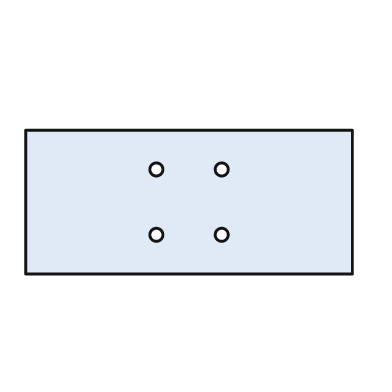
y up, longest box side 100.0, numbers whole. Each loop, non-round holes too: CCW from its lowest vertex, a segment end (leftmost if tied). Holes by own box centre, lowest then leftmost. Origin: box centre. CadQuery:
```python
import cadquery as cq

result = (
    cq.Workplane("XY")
    .moveTo(-50.0, -22.0)
    .lineTo(50.0, -22.0)
    .lineTo(50.0, 22.0)
    .lineTo(-50.0, 22.0)
    .close()
    .moveTo(-10.0, -10.0)
    .circle(2.0)
    .moveTo(10.0, -10.0)
    .circle(2.0)
    .moveTo(-10.0, 10.0)
    .circle(2.0)
    .moveTo(10.0, 10.0)
    .circle(2.0)
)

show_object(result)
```